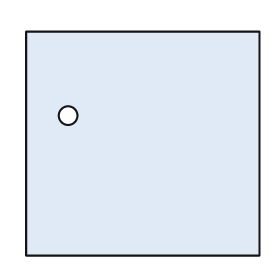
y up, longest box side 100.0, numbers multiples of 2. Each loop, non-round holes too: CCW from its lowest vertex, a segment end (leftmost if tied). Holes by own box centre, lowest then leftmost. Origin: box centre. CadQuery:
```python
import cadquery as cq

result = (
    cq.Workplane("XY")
    .moveTo(-50.0, -48.0)
    .lineTo(50.0, -48.0)
    .lineTo(50.0, 48.0)
    .lineTo(-50.0, 48.0)
    .close()
    .moveTo(-32.0, 12.0)
    .circle(4.0)
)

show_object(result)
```